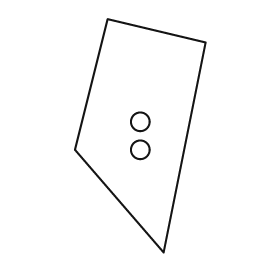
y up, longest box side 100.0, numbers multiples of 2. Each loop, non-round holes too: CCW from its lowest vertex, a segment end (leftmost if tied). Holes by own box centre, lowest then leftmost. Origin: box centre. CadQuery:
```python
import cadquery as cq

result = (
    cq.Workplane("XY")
    .moveTo(10.0, -50.0)
    .lineTo(28.0, 40.0)
    .lineTo(-14.0, 50.0)
    .lineTo(-28.0, -6.0)
    .close()
    .moveTo(0.0, -6.0)
    .circle(4.0)
    .moveTo(0.0, 6.0)
    .circle(4.0)
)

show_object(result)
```